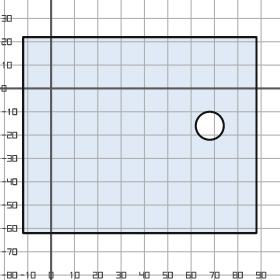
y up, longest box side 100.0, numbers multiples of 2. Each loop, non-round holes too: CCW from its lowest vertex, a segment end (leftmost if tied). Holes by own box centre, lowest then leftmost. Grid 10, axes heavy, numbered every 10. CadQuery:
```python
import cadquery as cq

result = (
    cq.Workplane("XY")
    .moveTo(-12.0, -62.0)
    .lineTo(88.0, -62.0)
    .lineTo(88.0, 22.0)
    .lineTo(-12.0, 22.0)
    .close()
    .moveTo(68.0, -16.0)
    .circle(6.0)
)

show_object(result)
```